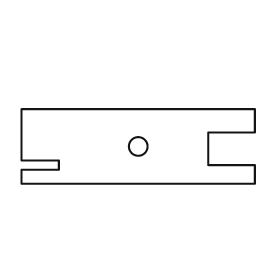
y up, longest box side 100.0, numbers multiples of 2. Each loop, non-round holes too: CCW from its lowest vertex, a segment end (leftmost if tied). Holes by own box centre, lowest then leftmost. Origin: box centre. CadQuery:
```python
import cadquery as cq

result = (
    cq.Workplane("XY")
    .moveTo(-50.0, -16.0)
    .lineTo(50.0, -16.0)
    .lineTo(50.0, -8.0)
    .lineTo(30.0, -8.0)
    .lineTo(30.0, 6.0)
    .lineTo(50.0, 6.0)
    .lineTo(50.0, 16.0)
    .lineTo(-50.0, 16.0)
    .lineTo(-50.0, -6.0)
    .lineTo(-34.0, -6.0)
    .lineTo(-34.0, -10.0)
    .lineTo(-50.0, -10.0)
    .close()
    .moveTo(0.0, 0.0)
    .circle(4.0)
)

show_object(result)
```